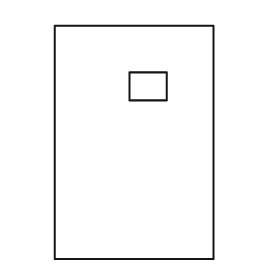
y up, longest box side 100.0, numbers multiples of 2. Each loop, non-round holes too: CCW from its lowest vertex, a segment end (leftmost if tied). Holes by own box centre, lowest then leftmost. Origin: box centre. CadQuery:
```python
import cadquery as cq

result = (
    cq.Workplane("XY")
    .moveTo(-34.0, -50.0)
    .lineTo(34.0, -50.0)
    .lineTo(34.0, 50.0)
    .lineTo(-34.0, 50.0)
    .close()
    .moveTo(-2.0, 18.0)
    .lineTo(14.0, 18.0)
    .lineTo(14.0, 30.0)
    .lineTo(-2.0, 30.0)
    .close()
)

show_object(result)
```